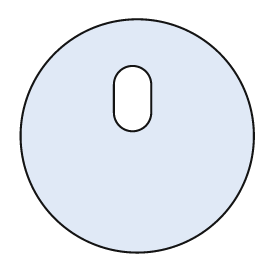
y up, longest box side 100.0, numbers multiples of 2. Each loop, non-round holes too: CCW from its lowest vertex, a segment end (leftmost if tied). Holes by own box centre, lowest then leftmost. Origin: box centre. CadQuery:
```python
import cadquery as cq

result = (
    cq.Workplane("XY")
    .moveTo(0.0, 0.0)
    .circle(50.0)
    .moveTo(-10.0, 10.0)
    .threePointArc((-2.0, 2.0), (6.0, 10.0))
    .lineTo(6.0, 22.0)
    .threePointArc((-2.0, 30.0), (-10.0, 22.0))
    .close()
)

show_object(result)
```